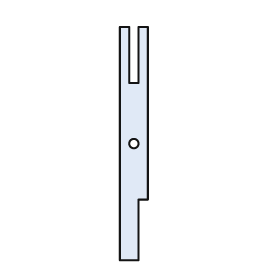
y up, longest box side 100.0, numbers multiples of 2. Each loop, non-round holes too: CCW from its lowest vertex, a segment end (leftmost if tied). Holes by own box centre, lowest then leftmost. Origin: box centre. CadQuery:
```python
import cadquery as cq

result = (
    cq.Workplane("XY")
    .moveTo(-6.0, -50.0)
    .lineTo(2.0, -50.0)
    .lineTo(2.0, -24.0)
    .lineTo(6.0, -24.0)
    .lineTo(6.0, 50.0)
    .lineTo(2.0, 50.0)
    .lineTo(2.0, 26.0)
    .lineTo(-2.0, 26.0)
    .lineTo(-2.0, 50.0)
    .lineTo(-6.0, 50.0)
    .close()
    .moveTo(0.0, 0.0)
    .circle(2.0)
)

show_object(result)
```